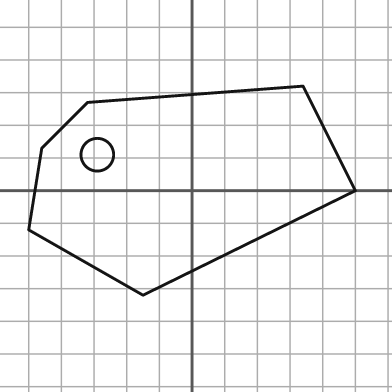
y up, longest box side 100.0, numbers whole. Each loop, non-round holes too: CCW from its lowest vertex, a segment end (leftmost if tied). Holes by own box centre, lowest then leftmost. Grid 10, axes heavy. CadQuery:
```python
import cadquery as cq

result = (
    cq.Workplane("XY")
    .moveTo(-15.0, -32.0)
    .lineTo(50.0, 0.0)
    .lineTo(34.0, 32.0)
    .lineTo(-32.0, 27.0)
    .lineTo(-46.0, 13.0)
    .lineTo(-50.0, -12.0)
    .close()
    .moveTo(-29.0, 11.0)
    .circle(5.0)
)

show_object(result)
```